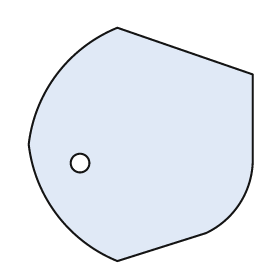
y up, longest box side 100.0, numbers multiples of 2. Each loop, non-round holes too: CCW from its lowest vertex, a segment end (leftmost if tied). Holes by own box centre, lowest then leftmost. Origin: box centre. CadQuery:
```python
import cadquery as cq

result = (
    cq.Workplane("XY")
    .moveTo(-10.0, -50.0)
    .lineTo(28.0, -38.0)
    .threePointArc((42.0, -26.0), (48.0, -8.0))
    .lineTo(48.0, 30.0)
    .lineTo(-10.0, 50.0)
    .threePointArc((-36.0, 30.0), (-48.0, 0.0))
    .threePointArc((-36.0, -30.0), (-10.0, -50.0))
    .close()
    .moveTo(-26.0, -8.0)
    .circle(4.0)
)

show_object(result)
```